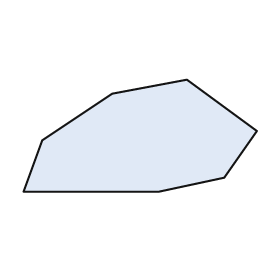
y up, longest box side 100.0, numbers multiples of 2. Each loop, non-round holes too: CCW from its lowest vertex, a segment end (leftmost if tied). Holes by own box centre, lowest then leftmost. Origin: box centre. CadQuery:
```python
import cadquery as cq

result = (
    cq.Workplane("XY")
    .moveTo(-50.0, -24.0)
    .lineTo(8.0, -24.0)
    .lineTo(36.0, -18.0)
    .lineTo(50.0, 2.0)
    .lineTo(20.0, 24.0)
    .lineTo(-12.0, 18.0)
    .lineTo(-42.0, -2.0)
    .close()
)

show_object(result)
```